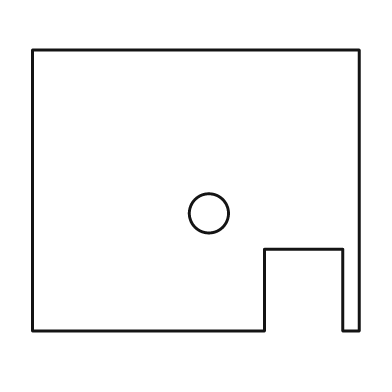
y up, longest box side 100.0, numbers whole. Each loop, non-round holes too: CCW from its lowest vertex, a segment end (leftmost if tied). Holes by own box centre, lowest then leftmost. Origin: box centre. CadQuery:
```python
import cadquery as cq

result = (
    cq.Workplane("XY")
    .moveTo(-50.0, -43.0)
    .lineTo(21.0, -43.0)
    .lineTo(21.0, -18.0)
    .lineTo(45.0, -18.0)
    .lineTo(45.0, -43.0)
    .lineTo(50.0, -43.0)
    .lineTo(50.0, 43.0)
    .lineTo(-50.0, 43.0)
    .close()
    .moveTo(4.0, -7.0)
    .circle(6.0)
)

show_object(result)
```